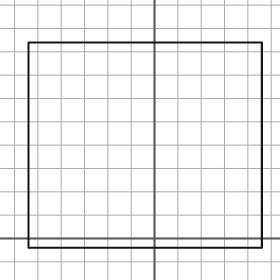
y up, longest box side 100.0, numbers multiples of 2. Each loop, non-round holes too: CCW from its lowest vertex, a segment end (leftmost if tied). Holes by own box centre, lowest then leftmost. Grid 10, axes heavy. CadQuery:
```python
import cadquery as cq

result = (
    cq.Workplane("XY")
    .moveTo(-54.0, -4.0)
    .lineTo(46.0, -4.0)
    .lineTo(46.0, 84.0)
    .lineTo(-54.0, 84.0)
    .close()
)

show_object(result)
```